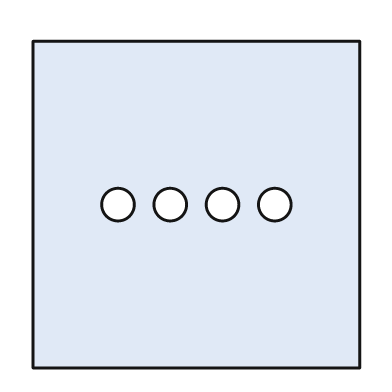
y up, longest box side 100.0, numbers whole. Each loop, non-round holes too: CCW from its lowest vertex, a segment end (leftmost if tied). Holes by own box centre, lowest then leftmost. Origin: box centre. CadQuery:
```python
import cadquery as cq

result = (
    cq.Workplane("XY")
    .moveTo(-50.0, -50.0)
    .lineTo(50.0, -50.0)
    .lineTo(50.0, 50.0)
    .lineTo(-50.0, 50.0)
    .close()
    .moveTo(-24.0, 0.0)
    .circle(5.0)
    .moveTo(-8.0, 0.0)
    .circle(5.0)
    .moveTo(8.0, 0.0)
    .circle(5.0)
    .moveTo(24.0, 0.0)
    .circle(5.0)
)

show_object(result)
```